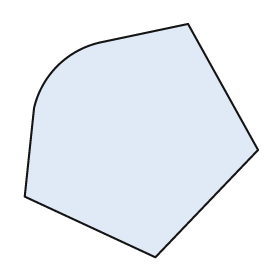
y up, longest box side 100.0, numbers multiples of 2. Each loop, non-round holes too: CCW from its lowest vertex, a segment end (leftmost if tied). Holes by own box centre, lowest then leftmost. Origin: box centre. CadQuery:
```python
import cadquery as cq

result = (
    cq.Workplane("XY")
    .moveTo(6.0, -50.0)
    .lineTo(50.0, -4.0)
    .lineTo(20.0, 50.0)
    .lineTo(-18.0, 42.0)
    .threePointArc((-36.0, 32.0), (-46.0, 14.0))
    .lineTo(-50.0, -24.0)
    .close()
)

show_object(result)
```